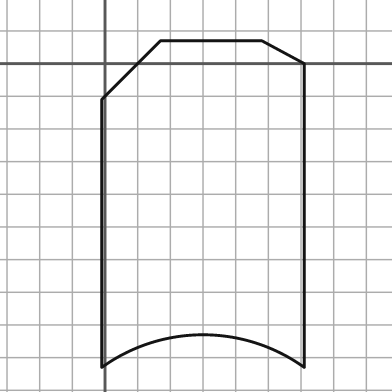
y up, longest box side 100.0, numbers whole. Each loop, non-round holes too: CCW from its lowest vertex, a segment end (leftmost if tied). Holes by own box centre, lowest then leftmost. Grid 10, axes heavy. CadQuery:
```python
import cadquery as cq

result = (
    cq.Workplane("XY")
    .moveTo(-1.0, -93.0)
    .threePointArc((30.0, -83.0), (61.0, -93.0))
    .lineTo(61.0, 0.0)
    .lineTo(48.0, 7.0)
    .lineTo(17.0, 7.0)
    .lineTo(-1.0, -11.0)
    .close()
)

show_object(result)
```